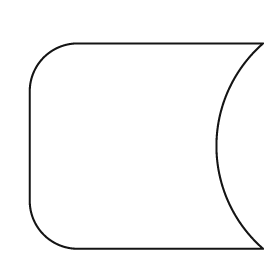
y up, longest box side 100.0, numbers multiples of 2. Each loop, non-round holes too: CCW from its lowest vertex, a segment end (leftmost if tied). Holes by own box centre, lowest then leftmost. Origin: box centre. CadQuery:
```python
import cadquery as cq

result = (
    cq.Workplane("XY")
    .moveTo(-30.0, -44.0)
    .lineTo(50.0, -44.0)
    .threePointArc((30.0, 0.0), (50.0, 44.0))
    .lineTo(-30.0, 44.0)
    .threePointArc((-44.0, 38.0), (-50.0, 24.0))
    .lineTo(-50.0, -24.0)
    .threePointArc((-44.0, -38.0), (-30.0, -44.0))
    .close()
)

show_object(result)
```